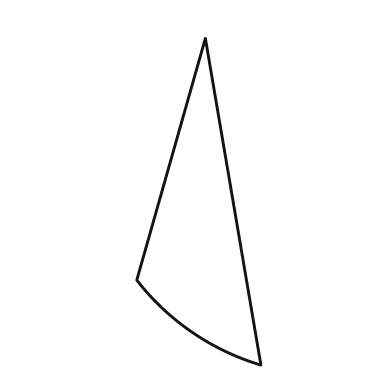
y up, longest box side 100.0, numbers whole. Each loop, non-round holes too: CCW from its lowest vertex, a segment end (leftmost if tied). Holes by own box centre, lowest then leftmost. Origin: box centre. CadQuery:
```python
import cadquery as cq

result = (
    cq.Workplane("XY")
    .moveTo(19.0, -50.0)
    .lineTo(2.0, 50.0)
    .lineTo(-19.0, -24.0)
    .threePointArc((-2.0, -40.0), (19.0, -50.0))
    .close()
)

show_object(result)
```